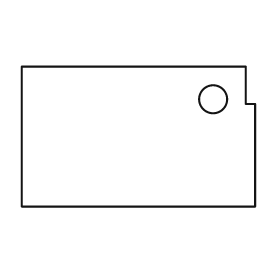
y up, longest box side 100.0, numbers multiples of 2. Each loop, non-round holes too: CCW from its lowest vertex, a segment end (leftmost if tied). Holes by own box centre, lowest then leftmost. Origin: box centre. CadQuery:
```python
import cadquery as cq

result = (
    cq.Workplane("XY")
    .moveTo(-50.0, -30.0)
    .lineTo(50.0, -30.0)
    .lineTo(50.0, 14.0)
    .lineTo(46.0, 14.0)
    .lineTo(46.0, 30.0)
    .lineTo(-50.0, 30.0)
    .close()
    .moveTo(32.0, 16.0)
    .circle(6.0)
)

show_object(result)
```